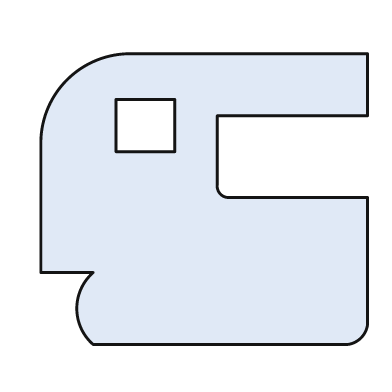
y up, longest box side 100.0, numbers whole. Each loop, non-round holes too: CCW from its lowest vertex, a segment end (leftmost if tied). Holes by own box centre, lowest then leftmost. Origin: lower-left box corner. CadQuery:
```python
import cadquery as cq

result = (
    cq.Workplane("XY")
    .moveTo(16.0, 0.0)
    .lineTo(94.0, 0.0)
    .threePointArc((98.0, 2.0), (100.0, 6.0))
    .lineTo(100.0, 45.0)
    .lineTo(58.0, 45.0)
    .threePointArc((55.0, 46.0), (54.0, 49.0))
    .lineTo(54.0, 70.0)
    .lineTo(100.0, 70.0)
    .lineTo(100.0, 89.0)
    .lineTo(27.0, 89.0)
    .threePointArc((8.0, 81.0), (0.0, 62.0))
    .lineTo(0.0, 22.0)
    .lineTo(16.0, 22.0)
    .threePointArc((11.0, 11.0), (16.0, 0.0))
    .close()
    .moveTo(23.0, 59.0)
    .lineTo(41.0, 59.0)
    .lineTo(41.0, 75.0)
    .lineTo(23.0, 75.0)
    .close()
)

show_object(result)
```